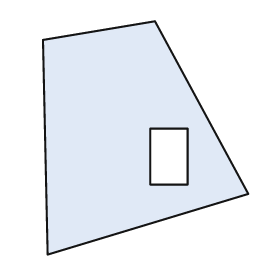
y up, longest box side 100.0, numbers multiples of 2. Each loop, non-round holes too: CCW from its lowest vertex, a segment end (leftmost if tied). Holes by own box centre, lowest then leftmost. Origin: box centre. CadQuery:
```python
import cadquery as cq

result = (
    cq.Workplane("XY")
    .moveTo(-42.0, -50.0)
    .lineTo(44.0, -24.0)
    .lineTo(4.0, 50.0)
    .lineTo(-44.0, 42.0)
    .close()
    .moveTo(2.0, -20.0)
    .lineTo(18.0, -20.0)
    .lineTo(18.0, 4.0)
    .lineTo(2.0, 4.0)
    .close()
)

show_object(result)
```